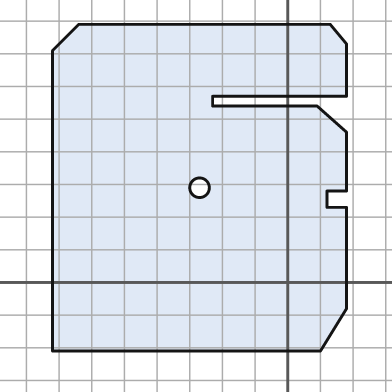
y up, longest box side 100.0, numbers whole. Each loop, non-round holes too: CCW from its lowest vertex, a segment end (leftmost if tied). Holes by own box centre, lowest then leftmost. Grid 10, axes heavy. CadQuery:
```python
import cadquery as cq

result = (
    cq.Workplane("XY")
    .moveTo(-72.0, -21.0)
    .lineTo(10.0, -21.0)
    .lineTo(18.0, -8.0)
    .lineTo(18.0, 23.0)
    .lineTo(12.0, 23.0)
    .lineTo(12.0, 28.0)
    .lineTo(18.0, 28.0)
    .lineTo(18.0, 46.0)
    .lineTo(9.0, 54.0)
    .lineTo(-23.0, 54.0)
    .lineTo(-23.0, 57.0)
    .lineTo(18.0, 57.0)
    .lineTo(18.0, 73.0)
    .lineTo(13.0, 79.0)
    .lineTo(-64.0, 79.0)
    .lineTo(-72.0, 71.0)
    .close()
    .moveTo(-27.0, 29.0)
    .circle(3.0)
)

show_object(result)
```